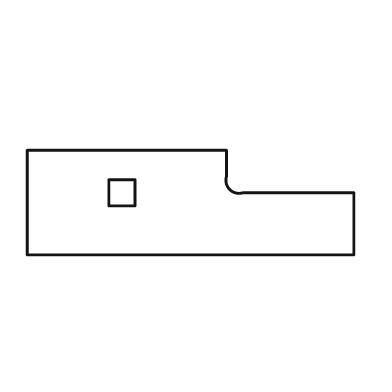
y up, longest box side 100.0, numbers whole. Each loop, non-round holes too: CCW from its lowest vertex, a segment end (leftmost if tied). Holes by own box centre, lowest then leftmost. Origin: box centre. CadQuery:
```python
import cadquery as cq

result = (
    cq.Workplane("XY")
    .moveTo(-50.0, -16.0)
    .lineTo(50.0, -16.0)
    .lineTo(50.0, 3.0)
    .lineTo(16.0, 3.0)
    .threePointArc((12.0, 4.0), (11.0, 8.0))
    .lineTo(11.0, 16.0)
    .lineTo(-50.0, 16.0)
    .close()
    .moveTo(-25.0, -1.0)
    .lineTo(-17.0, -1.0)
    .lineTo(-17.0, 7.0)
    .lineTo(-25.0, 7.0)
    .close()
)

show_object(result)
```